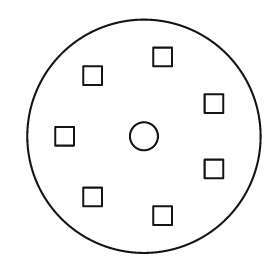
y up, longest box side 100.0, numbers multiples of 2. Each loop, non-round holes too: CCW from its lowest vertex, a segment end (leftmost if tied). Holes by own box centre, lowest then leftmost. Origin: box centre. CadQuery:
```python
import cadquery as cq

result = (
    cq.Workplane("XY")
    .moveTo(0.0, 0.0)
    .circle(50.0)
    .moveTo(4.0, -38.0)
    .lineTo(12.0, -38.0)
    .lineTo(12.0, -30.0)
    .lineTo(4.0, -30.0)
    .close()
    .moveTo(-26.0, -30.0)
    .lineTo(-18.0, -30.0)
    .lineTo(-18.0, -22.0)
    .lineTo(-26.0, -22.0)
    .close()
    .moveTo(26.0, -18.0)
    .lineTo(34.0, -18.0)
    .lineTo(34.0, -10.0)
    .lineTo(26.0, -10.0)
    .close()
    .moveTo(-38.0, -4.0)
    .lineTo(-30.0, -4.0)
    .lineTo(-30.0, 4.0)
    .lineTo(-38.0, 4.0)
    .close()
    .moveTo(0.0, 0.0)
    .circle(6.0)
    .moveTo(26.0, 10.0)
    .lineTo(34.0, 10.0)
    .lineTo(34.0, 18.0)
    .lineTo(26.0, 18.0)
    .close()
    .moveTo(-26.0, 22.0)
    .lineTo(-18.0, 22.0)
    .lineTo(-18.0, 30.0)
    .lineTo(-26.0, 30.0)
    .close()
    .moveTo(4.0, 30.0)
    .lineTo(12.0, 30.0)
    .lineTo(12.0, 38.0)
    .lineTo(4.0, 38.0)
    .close()
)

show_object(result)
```